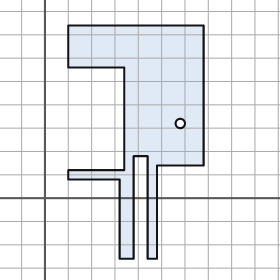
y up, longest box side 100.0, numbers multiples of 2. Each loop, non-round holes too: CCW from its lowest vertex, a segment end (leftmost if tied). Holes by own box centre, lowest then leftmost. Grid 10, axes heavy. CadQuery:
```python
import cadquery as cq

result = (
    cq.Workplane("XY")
    .moveTo(32.0, -26.0)
    .lineTo(38.0, -26.0)
    .lineTo(38.0, 18.0)
    .lineTo(44.0, 18.0)
    .lineTo(44.0, -26.0)
    .lineTo(48.0, -26.0)
    .lineTo(48.0, 14.0)
    .lineTo(68.0, 14.0)
    .lineTo(68.0, 74.0)
    .lineTo(10.0, 74.0)
    .lineTo(10.0, 56.0)
    .lineTo(34.0, 56.0)
    .lineTo(34.0, 12.0)
    .lineTo(10.0, 12.0)
    .lineTo(10.0, 8.0)
    .lineTo(32.0, 8.0)
    .close()
    .moveTo(58.0, 32.0)
    .circle(2.0)
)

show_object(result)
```